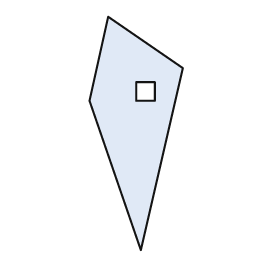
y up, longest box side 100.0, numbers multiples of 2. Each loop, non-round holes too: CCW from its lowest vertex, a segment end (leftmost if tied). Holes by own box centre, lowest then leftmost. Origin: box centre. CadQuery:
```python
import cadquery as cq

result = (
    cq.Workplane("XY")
    .moveTo(2.0, -50.0)
    .lineTo(20.0, 28.0)
    .lineTo(-12.0, 50.0)
    .lineTo(-20.0, 14.0)
    .close()
    .moveTo(0.0, 14.0)
    .lineTo(8.0, 14.0)
    .lineTo(8.0, 22.0)
    .lineTo(0.0, 22.0)
    .close()
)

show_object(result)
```